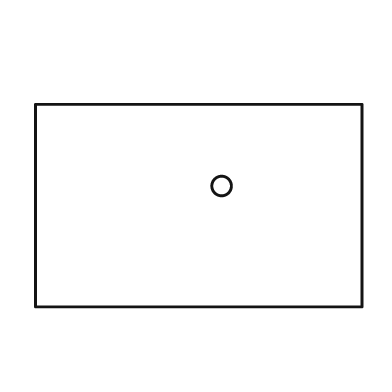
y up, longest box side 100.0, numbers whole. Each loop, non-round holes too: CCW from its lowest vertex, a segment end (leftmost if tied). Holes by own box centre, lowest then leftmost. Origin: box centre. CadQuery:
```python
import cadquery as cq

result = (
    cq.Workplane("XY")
    .moveTo(-50.0, -31.0)
    .lineTo(50.0, -31.0)
    .lineTo(50.0, 31.0)
    .lineTo(-50.0, 31.0)
    .close()
    .moveTo(7.0, 6.0)
    .circle(3.0)
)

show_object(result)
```